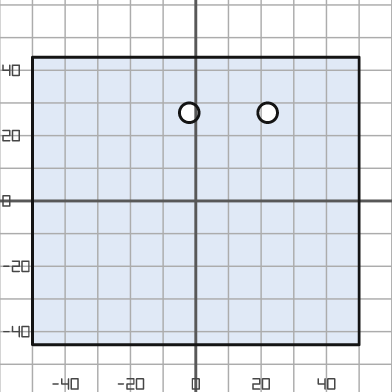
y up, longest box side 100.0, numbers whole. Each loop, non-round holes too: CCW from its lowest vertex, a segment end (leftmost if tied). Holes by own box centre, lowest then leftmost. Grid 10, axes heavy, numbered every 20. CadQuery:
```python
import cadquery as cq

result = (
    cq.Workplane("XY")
    .moveTo(-50.0, -44.0)
    .lineTo(50.0, -44.0)
    .lineTo(50.0, 44.0)
    .lineTo(-50.0, 44.0)
    .close()
    .moveTo(-2.0, 27.0)
    .circle(3.0)
    .moveTo(22.0, 27.0)
    .circle(3.0)
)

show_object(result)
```